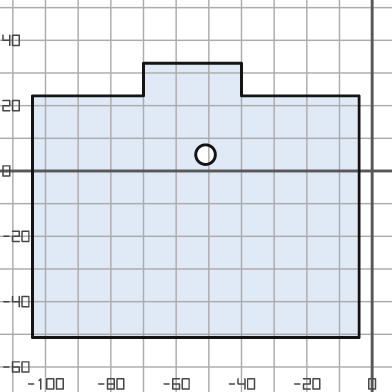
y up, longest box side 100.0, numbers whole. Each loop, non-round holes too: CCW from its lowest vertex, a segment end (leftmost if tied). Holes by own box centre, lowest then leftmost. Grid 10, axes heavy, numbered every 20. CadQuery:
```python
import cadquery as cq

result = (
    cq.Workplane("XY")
    .moveTo(-104.0, -51.0)
    .lineTo(-4.0, -51.0)
    .lineTo(-4.0, 23.0)
    .lineTo(-40.0, 23.0)
    .lineTo(-40.0, 33.0)
    .lineTo(-70.0, 33.0)
    .lineTo(-70.0, 23.0)
    .lineTo(-104.0, 23.0)
    .close()
    .moveTo(-51.0, 5.0)
    .circle(3.0)
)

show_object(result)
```